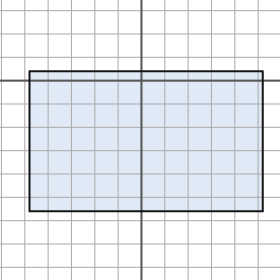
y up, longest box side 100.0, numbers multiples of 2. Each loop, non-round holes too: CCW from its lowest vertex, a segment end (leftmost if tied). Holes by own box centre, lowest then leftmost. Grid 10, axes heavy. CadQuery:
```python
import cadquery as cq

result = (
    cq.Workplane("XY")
    .moveTo(-48.0, -56.0)
    .lineTo(52.0, -56.0)
    .lineTo(52.0, 4.0)
    .lineTo(-48.0, 4.0)
    .close()
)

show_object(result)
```